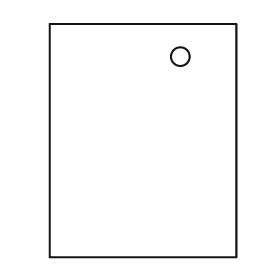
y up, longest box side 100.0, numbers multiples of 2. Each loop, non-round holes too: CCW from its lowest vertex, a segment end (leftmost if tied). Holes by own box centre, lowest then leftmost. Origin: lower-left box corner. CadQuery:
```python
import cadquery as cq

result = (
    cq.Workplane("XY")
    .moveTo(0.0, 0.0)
    .lineTo(80.0, 0.0)
    .lineTo(80.0, 100.0)
    .lineTo(0.0, 100.0)
    .close()
    .moveTo(56.0, 86.0)
    .circle(4.0)
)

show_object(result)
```